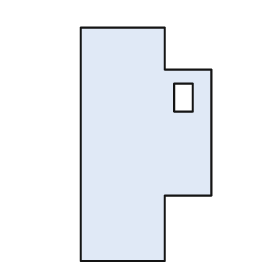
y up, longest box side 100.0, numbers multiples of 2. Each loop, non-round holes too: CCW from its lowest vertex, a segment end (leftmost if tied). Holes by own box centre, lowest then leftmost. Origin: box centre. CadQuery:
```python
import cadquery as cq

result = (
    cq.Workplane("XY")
    .moveTo(-28.0, -50.0)
    .lineTo(8.0, -50.0)
    .lineTo(8.0, -22.0)
    .lineTo(28.0, -22.0)
    .lineTo(28.0, 32.0)
    .lineTo(8.0, 32.0)
    .lineTo(8.0, 50.0)
    .lineTo(-28.0, 50.0)
    .close()
    .moveTo(12.0, 14.0)
    .lineTo(20.0, 14.0)
    .lineTo(20.0, 26.0)
    .lineTo(12.0, 26.0)
    .close()
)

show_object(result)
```